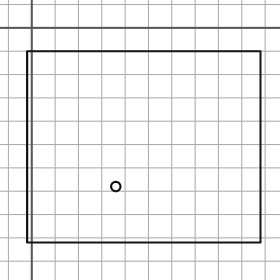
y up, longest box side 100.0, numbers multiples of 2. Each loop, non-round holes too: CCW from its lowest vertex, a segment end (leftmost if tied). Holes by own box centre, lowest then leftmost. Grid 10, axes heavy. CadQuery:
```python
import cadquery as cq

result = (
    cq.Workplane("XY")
    .moveTo(-2.0, -92.0)
    .lineTo(98.0, -92.0)
    .lineTo(98.0, -10.0)
    .lineTo(-2.0, -10.0)
    .close()
    .moveTo(36.0, -68.0)
    .circle(2.0)
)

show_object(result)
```